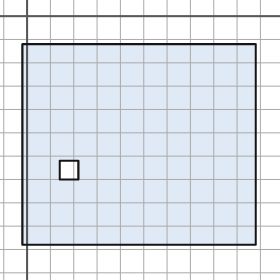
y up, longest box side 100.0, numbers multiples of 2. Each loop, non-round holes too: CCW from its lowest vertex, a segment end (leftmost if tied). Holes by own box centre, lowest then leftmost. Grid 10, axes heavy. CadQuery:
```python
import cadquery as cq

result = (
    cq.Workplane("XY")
    .moveTo(-2.0, -98.0)
    .lineTo(98.0, -98.0)
    .lineTo(98.0, -12.0)
    .lineTo(-2.0, -12.0)
    .close()
    .moveTo(14.0, -70.0)
    .lineTo(22.0, -70.0)
    .lineTo(22.0, -62.0)
    .lineTo(14.0, -62.0)
    .close()
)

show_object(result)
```